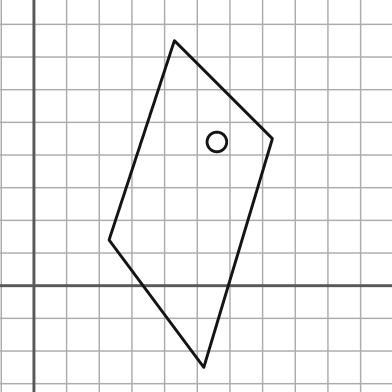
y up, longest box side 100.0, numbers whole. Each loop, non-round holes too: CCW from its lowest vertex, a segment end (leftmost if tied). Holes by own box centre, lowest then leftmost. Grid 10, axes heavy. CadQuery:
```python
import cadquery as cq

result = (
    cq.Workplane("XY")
    .moveTo(52.0, -25.0)
    .lineTo(73.0, 45.0)
    .lineTo(43.0, 75.0)
    .lineTo(23.0, 14.0)
    .close()
    .moveTo(56.0, 44.0)
    .circle(3.0)
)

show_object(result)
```